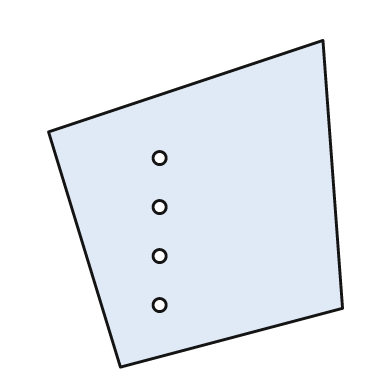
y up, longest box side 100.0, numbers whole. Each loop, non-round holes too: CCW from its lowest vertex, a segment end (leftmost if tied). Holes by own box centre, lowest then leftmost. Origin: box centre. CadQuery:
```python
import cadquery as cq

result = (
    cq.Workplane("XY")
    .moveTo(-23.0, -50.0)
    .lineTo(45.0, -32.0)
    .lineTo(39.0, 50.0)
    .lineTo(-45.0, 22.0)
    .close()
    .moveTo(-11.0, -31.0)
    .circle(2.0)
    .moveTo(-11.0, -16.0)
    .circle(2.0)
    .moveTo(-11.0, -1.0)
    .circle(2.0)
    .moveTo(-11.0, 14.0)
    .circle(2.0)
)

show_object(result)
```